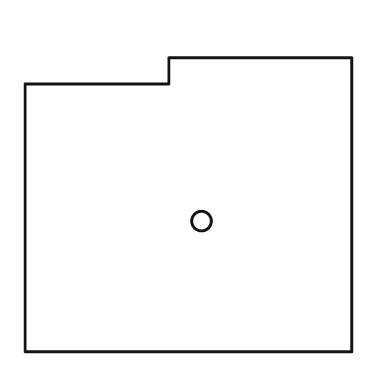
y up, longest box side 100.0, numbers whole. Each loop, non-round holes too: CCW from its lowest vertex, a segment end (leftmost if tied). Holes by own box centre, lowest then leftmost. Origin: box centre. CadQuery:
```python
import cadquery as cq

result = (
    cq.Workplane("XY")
    .moveTo(-50.0, -45.0)
    .lineTo(50.0, -45.0)
    .lineTo(50.0, 45.0)
    .lineTo(-6.0, 45.0)
    .lineTo(-6.0, 37.0)
    .lineTo(-50.0, 37.0)
    .close()
    .moveTo(4.0, -5.0)
    .circle(3.0)
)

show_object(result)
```